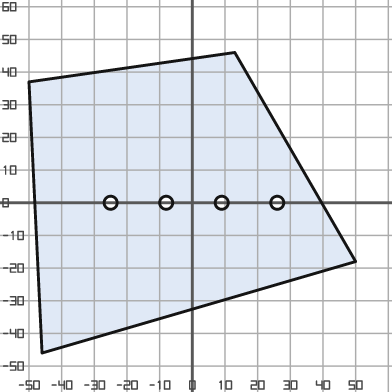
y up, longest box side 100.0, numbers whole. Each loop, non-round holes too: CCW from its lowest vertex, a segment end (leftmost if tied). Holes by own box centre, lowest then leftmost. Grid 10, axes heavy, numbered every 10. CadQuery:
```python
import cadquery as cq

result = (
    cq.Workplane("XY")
    .moveTo(-46.0, -46.0)
    .lineTo(50.0, -18.0)
    .lineTo(13.0, 46.0)
    .lineTo(-50.0, 37.0)
    .close()
    .moveTo(-25.0, 0.0)
    .circle(2.0)
    .moveTo(-8.0, 0.0)
    .circle(2.0)
    .moveTo(9.0, 0.0)
    .circle(2.0)
    .moveTo(26.0, 0.0)
    .circle(2.0)
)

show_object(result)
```